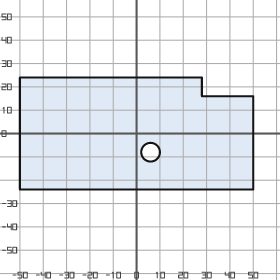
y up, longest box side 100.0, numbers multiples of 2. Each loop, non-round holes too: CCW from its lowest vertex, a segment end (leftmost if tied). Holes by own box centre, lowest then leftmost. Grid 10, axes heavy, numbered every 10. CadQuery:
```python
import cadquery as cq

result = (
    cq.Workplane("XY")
    .moveTo(-50.0, -24.0)
    .lineTo(50.0, -24.0)
    .lineTo(50.0, 16.0)
    .lineTo(28.0, 16.0)
    .lineTo(28.0, 24.0)
    .lineTo(-50.0, 24.0)
    .close()
    .moveTo(6.0, -8.0)
    .circle(4.0)
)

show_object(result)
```